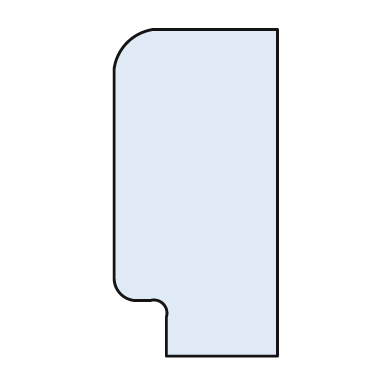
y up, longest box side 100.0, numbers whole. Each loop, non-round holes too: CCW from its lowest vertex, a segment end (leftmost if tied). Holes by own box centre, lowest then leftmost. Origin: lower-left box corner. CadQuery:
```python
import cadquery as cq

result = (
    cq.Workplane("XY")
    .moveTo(16.0, 0.0)
    .lineTo(50.0, 0.0)
    .lineTo(50.0, 100.0)
    .lineTo(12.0, 100.0)
    .threePointArc((4.0, 96.0), (0.0, 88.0))
    .lineTo(0.0, 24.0)
    .threePointArc((2.0, 19.0), (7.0, 17.0))
    .lineTo(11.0, 17.0)
    .threePointArc((15.0, 16.0), (16.0, 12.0))
    .close()
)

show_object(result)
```